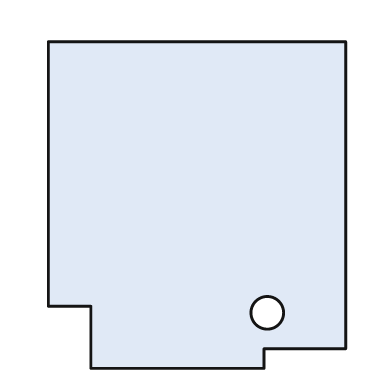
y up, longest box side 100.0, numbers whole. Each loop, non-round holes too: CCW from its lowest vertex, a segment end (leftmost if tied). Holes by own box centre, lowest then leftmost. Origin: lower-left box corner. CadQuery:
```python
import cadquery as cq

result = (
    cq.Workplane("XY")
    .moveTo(13.0, 0.0)
    .lineTo(66.0, 0.0)
    .lineTo(66.0, 6.0)
    .lineTo(91.0, 6.0)
    .lineTo(91.0, 100.0)
    .lineTo(0.0, 100.0)
    .lineTo(0.0, 19.0)
    .lineTo(13.0, 19.0)
    .close()
    .moveTo(67.0, 17.0)
    .circle(5.0)
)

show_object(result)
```